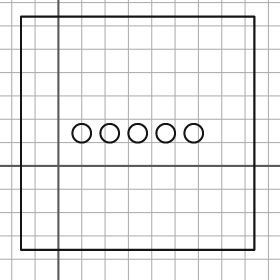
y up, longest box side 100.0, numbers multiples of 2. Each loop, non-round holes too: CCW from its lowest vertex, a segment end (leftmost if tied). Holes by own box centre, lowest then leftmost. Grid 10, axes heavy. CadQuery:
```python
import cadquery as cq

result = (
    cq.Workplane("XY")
    .moveTo(-16.0, -36.0)
    .lineTo(84.0, -36.0)
    .lineTo(84.0, 64.0)
    .lineTo(-16.0, 64.0)
    .close()
    .moveTo(10.0, 14.0)
    .circle(4.0)
    .moveTo(22.0, 14.0)
    .circle(4.0)
    .moveTo(34.0, 14.0)
    .circle(4.0)
    .moveTo(46.0, 14.0)
    .circle(4.0)
    .moveTo(58.0, 14.0)
    .circle(4.0)
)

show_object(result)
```